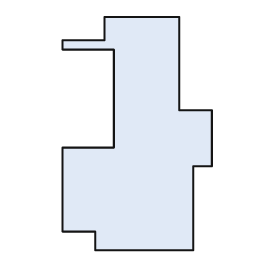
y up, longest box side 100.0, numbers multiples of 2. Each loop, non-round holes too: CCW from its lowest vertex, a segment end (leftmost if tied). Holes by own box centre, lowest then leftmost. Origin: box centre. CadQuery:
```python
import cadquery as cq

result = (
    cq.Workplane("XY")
    .moveTo(-18.0, -50.0)
    .lineTo(24.0, -50.0)
    .lineTo(24.0, -14.0)
    .lineTo(32.0, -14.0)
    .lineTo(32.0, 10.0)
    .lineTo(18.0, 10.0)
    .lineTo(18.0, 50.0)
    .lineTo(-14.0, 50.0)
    .lineTo(-14.0, 40.0)
    .lineTo(-32.0, 40.0)
    .lineTo(-32.0, 36.0)
    .lineTo(-10.0, 36.0)
    .lineTo(-10.0, -6.0)
    .lineTo(-32.0, -6.0)
    .lineTo(-32.0, -42.0)
    .lineTo(-18.0, -42.0)
    .close()
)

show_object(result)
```